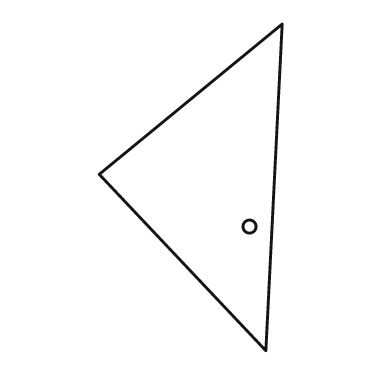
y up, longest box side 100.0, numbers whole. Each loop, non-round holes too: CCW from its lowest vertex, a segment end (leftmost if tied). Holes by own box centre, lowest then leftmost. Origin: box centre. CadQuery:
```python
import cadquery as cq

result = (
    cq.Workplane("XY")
    .moveTo(23.0, -50.0)
    .lineTo(28.0, 50.0)
    .lineTo(-28.0, 4.0)
    .close()
    .moveTo(18.0, -12.0)
    .circle(2.0)
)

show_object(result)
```